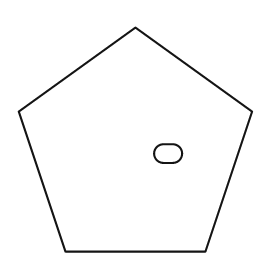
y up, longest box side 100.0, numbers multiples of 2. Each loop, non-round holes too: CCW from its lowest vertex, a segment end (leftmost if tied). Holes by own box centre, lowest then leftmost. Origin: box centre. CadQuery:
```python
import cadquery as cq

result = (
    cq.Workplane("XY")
    .moveTo(-30.0, -48.0)
    .lineTo(30.0, -48.0)
    .lineTo(50.0, 12.0)
    .lineTo(0.0, 48.0)
    .lineTo(-50.0, 12.0)
    .close()
    .moveTo(12.0, -10.0)
    .lineTo(16.0, -10.0)
    .threePointArc((20.0, -6.0), (16.0, -2.0))
    .lineTo(12.0, -2.0)
    .threePointArc((8.0, -6.0), (12.0, -10.0))
    .close()
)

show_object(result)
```